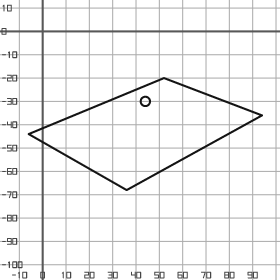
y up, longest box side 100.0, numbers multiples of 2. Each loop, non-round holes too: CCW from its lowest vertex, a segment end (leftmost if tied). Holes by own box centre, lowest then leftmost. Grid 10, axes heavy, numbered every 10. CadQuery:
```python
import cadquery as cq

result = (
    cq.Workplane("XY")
    .moveTo(36.0, -68.0)
    .lineTo(94.0, -36.0)
    .lineTo(52.0, -20.0)
    .lineTo(-6.0, -44.0)
    .close()
    .moveTo(44.0, -30.0)
    .circle(2.0)
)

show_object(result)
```